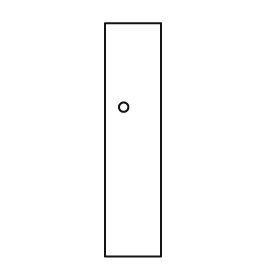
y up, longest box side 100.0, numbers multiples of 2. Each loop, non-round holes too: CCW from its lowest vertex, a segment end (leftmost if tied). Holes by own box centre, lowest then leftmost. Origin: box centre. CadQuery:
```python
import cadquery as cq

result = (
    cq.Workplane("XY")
    .moveTo(-12.0, -50.0)
    .lineTo(12.0, -50.0)
    .lineTo(12.0, 50.0)
    .lineTo(-12.0, 50.0)
    .close()
    .moveTo(-4.0, 14.0)
    .circle(2.0)
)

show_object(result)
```